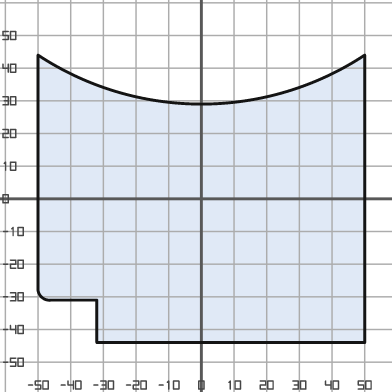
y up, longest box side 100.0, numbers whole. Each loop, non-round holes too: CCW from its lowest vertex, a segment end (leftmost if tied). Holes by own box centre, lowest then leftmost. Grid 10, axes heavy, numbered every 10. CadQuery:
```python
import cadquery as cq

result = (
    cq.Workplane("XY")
    .moveTo(-32.0, -44.0)
    .lineTo(50.0, -44.0)
    .lineTo(50.0, 44.0)
    .threePointArc((0.0, 29.0), (-50.0, 44.0))
    .lineTo(-50.0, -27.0)
    .threePointArc((-49.0, -30.0), (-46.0, -31.0))
    .lineTo(-32.0, -31.0)
    .close()
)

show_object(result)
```